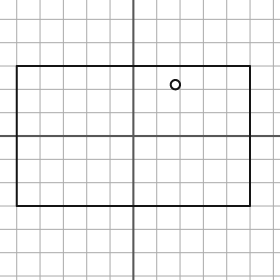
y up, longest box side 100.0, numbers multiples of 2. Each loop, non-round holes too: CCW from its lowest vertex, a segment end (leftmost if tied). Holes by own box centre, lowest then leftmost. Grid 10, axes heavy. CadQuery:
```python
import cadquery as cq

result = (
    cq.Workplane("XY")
    .moveTo(-50.0, -30.0)
    .lineTo(50.0, -30.0)
    .lineTo(50.0, 30.0)
    .lineTo(-50.0, 30.0)
    .close()
    .moveTo(18.0, 22.0)
    .circle(2.0)
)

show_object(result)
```